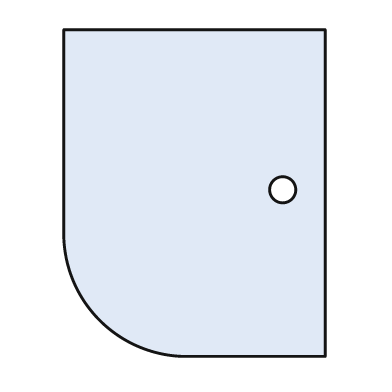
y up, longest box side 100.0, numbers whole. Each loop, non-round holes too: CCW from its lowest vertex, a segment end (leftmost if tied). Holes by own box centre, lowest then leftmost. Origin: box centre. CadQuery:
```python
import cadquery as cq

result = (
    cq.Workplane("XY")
    .moveTo(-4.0, -50.0)
    .lineTo(40.0, -50.0)
    .lineTo(40.0, 50.0)
    .lineTo(-40.0, 50.0)
    .lineTo(-40.0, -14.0)
    .threePointArc((-29.0, -39.0), (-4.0, -50.0))
    .close()
    .moveTo(27.0, 1.0)
    .circle(4.0)
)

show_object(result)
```